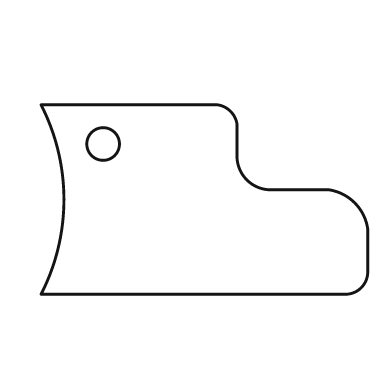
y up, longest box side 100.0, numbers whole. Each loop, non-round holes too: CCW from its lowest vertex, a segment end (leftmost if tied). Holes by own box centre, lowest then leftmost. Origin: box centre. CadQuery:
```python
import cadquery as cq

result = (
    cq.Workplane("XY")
    .moveTo(-50.0, -29.0)
    .lineTo(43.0, -29.0)
    .threePointArc((48.0, -27.0), (50.0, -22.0))
    .lineTo(50.0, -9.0)
    .threePointArc((46.0, -1.0), (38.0, 3.0))
    .lineTo(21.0, 3.0)
    .threePointArc((13.0, 6.0), (10.0, 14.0))
    .lineTo(10.0, 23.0)
    .threePointArc((8.0, 27.0), (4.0, 29.0))
    .lineTo(-50.0, 29.0)
    .threePointArc((-43.0, 0.0), (-50.0, -29.0))
    .close()
    .moveTo(-31.0, 17.0)
    .circle(5.0)
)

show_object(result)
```